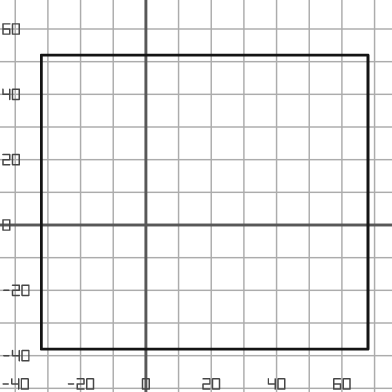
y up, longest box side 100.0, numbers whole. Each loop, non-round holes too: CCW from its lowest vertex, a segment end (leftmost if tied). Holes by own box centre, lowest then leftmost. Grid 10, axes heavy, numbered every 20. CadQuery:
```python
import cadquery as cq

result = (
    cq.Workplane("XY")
    .moveTo(-32.0, -38.0)
    .lineTo(68.0, -38.0)
    .lineTo(68.0, 52.0)
    .lineTo(-32.0, 52.0)
    .close()
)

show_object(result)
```